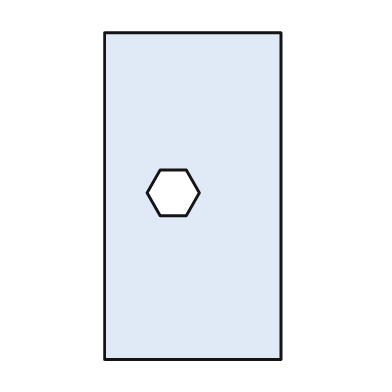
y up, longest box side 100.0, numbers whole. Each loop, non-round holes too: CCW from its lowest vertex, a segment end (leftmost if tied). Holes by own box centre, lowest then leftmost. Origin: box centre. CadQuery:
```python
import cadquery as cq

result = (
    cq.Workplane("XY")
    .moveTo(-27.0, -50.0)
    .lineTo(27.0, -50.0)
    .lineTo(27.0, 50.0)
    .lineTo(-27.0, 50.0)
    .close()
    .moveTo(-10.0, -6.0)
    .lineTo(-2.0, -6.0)
    .lineTo(2.0, 1.0)
    .lineTo(-2.0, 8.0)
    .lineTo(-10.0, 8.0)
    .lineTo(-14.0, 1.0)
    .close()
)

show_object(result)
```